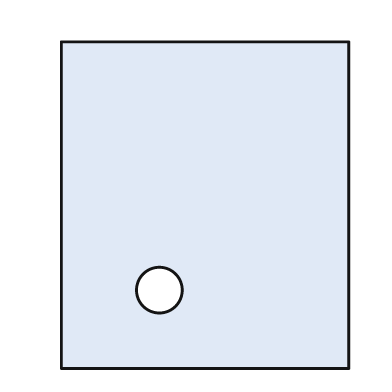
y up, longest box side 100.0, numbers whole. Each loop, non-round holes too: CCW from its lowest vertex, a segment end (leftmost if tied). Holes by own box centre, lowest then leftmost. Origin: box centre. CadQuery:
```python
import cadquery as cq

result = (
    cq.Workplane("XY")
    .moveTo(-44.0, -50.0)
    .lineTo(44.0, -50.0)
    .lineTo(44.0, 50.0)
    .lineTo(-44.0, 50.0)
    .close()
    .moveTo(-14.0, -26.0)
    .circle(7.0)
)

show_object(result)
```